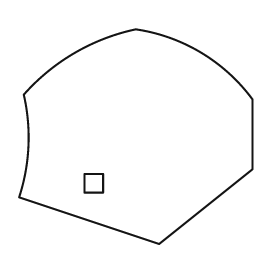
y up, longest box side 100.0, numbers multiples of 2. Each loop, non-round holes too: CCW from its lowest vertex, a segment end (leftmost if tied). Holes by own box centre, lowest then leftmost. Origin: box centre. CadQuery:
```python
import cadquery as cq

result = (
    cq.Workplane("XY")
    .moveTo(10.0, -46.0)
    .lineTo(50.0, -14.0)
    .lineTo(50.0, 16.0)
    .threePointArc((28.0, 36.0), (0.0, 46.0))
    .threePointArc((-26.0, 36.0), (-48.0, 18.0))
    .threePointArc((-46.0, -4.0), (-50.0, -26.0))
    .close()
    .moveTo(-22.0, -24.0)
    .lineTo(-14.0, -24.0)
    .lineTo(-14.0, -16.0)
    .lineTo(-22.0, -16.0)
    .close()
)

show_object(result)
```